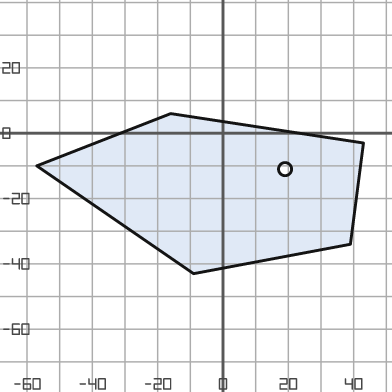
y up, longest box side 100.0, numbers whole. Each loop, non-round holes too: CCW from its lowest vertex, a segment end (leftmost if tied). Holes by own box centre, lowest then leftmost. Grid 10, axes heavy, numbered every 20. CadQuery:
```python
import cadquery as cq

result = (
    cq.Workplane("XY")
    .moveTo(-9.0, -43.0)
    .lineTo(39.0, -34.0)
    .lineTo(43.0, -3.0)
    .lineTo(-16.0, 6.0)
    .lineTo(-57.0, -10.0)
    .close()
    .moveTo(19.0, -11.0)
    .circle(2.0)
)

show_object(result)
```